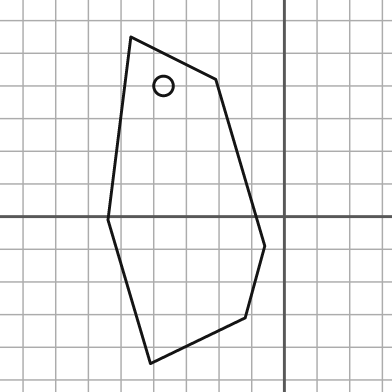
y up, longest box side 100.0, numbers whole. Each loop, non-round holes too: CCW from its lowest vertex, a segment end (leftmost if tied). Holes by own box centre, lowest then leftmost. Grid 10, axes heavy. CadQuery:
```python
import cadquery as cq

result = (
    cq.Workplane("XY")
    .moveTo(-41.0, -45.0)
    .lineTo(-12.0, -31.0)
    .lineTo(-6.0, -9.0)
    .lineTo(-21.0, 42.0)
    .lineTo(-47.0, 55.0)
    .lineTo(-54.0, -1.0)
    .close()
    .moveTo(-37.0, 40.0)
    .circle(3.0)
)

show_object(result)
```